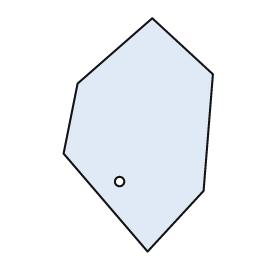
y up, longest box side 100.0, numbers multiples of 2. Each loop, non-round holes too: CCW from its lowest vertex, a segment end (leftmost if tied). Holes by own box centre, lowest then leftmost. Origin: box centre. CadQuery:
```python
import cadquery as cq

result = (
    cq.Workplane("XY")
    .moveTo(4.0, -50.0)
    .lineTo(28.0, -24.0)
    .lineTo(32.0, 26.0)
    .lineTo(6.0, 50.0)
    .lineTo(-26.0, 22.0)
    .lineTo(-32.0, -8.0)
    .close()
    .moveTo(-8.0, -20.0)
    .circle(2.0)
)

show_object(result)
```